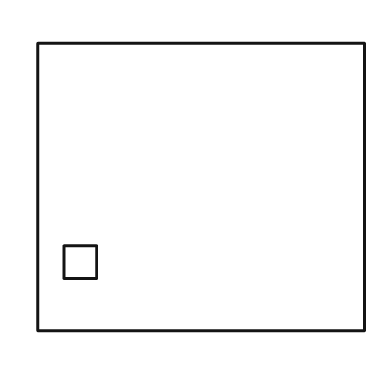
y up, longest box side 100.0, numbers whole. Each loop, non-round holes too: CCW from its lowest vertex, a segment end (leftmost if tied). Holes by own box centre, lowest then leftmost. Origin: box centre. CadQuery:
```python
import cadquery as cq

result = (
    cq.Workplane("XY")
    .moveTo(-50.0, -44.0)
    .lineTo(50.0, -44.0)
    .lineTo(50.0, 44.0)
    .lineTo(-50.0, 44.0)
    .close()
    .moveTo(-42.0, -28.0)
    .lineTo(-32.0, -28.0)
    .lineTo(-32.0, -18.0)
    .lineTo(-42.0, -18.0)
    .close()
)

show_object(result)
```